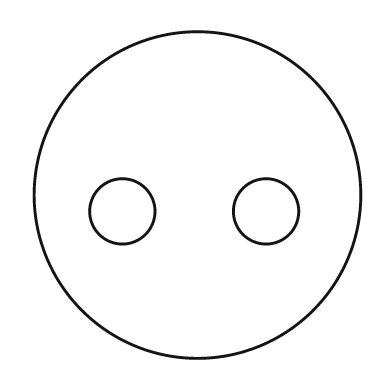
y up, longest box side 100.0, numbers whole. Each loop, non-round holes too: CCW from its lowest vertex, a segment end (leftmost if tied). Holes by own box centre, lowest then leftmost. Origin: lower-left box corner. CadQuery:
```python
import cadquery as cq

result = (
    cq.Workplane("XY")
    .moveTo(50.0, 50.0)
    .circle(50.0)
    .moveTo(27.0, 45.0)
    .circle(10.0)
    .moveTo(71.0, 45.0)
    .circle(10.0)
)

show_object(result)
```